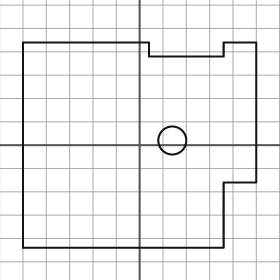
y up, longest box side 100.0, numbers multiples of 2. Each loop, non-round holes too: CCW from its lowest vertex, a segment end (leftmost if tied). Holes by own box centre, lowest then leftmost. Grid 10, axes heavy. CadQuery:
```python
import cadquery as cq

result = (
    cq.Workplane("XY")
    .moveTo(-50.0, -44.0)
    .lineTo(36.0, -44.0)
    .lineTo(36.0, -16.0)
    .lineTo(50.0, -16.0)
    .lineTo(50.0, 44.0)
    .lineTo(36.0, 44.0)
    .lineTo(36.0, 38.0)
    .lineTo(4.0, 38.0)
    .lineTo(4.0, 44.0)
    .lineTo(-50.0, 44.0)
    .close()
    .moveTo(14.0, 2.0)
    .circle(6.0)
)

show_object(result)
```